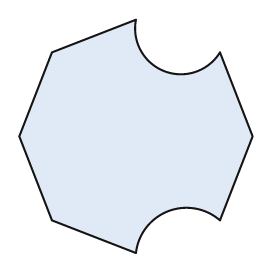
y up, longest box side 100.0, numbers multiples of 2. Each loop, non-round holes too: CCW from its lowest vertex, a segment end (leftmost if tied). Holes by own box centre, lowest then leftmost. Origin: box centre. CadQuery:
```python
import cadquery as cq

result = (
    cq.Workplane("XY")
    .moveTo(0.0, -50.0)
    .threePointArc((14.0, -32.0), (36.0, -36.0))
    .lineTo(50.0, 0.0)
    .lineTo(36.0, 36.0)
    .threePointArc((12.0, 28.0), (0.0, 50.0))
    .lineTo(-36.0, 36.0)
    .lineTo(-50.0, 0.0)
    .lineTo(-36.0, -36.0)
    .close()
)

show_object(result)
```